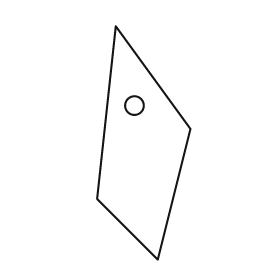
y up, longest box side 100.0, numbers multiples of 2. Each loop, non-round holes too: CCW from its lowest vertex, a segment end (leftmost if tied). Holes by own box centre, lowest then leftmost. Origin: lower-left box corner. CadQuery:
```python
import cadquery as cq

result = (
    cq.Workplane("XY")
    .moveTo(26.0, 0.0)
    .lineTo(40.0, 56.0)
    .lineTo(8.0, 100.0)
    .lineTo(0.0, 26.0)
    .close()
    .moveTo(16.0, 66.0)
    .circle(4.0)
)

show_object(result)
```